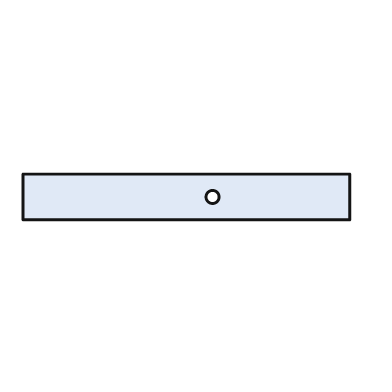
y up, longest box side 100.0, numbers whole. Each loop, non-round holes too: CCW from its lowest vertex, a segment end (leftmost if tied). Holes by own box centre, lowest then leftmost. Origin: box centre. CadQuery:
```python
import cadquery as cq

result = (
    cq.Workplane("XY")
    .moveTo(-50.0, -7.0)
    .lineTo(50.0, -7.0)
    .lineTo(50.0, 7.0)
    .lineTo(-50.0, 7.0)
    .close()
    .moveTo(8.0, 0.0)
    .circle(2.0)
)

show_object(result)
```